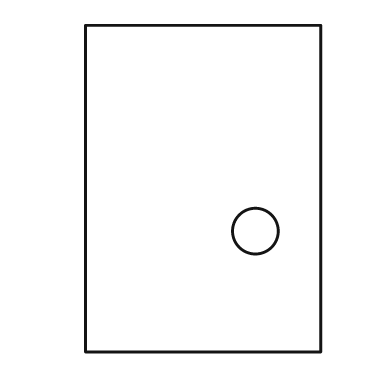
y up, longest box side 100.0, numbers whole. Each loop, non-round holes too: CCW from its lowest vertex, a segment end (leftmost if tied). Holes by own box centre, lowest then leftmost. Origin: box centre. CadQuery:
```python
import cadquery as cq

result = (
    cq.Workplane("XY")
    .moveTo(-36.0, -50.0)
    .lineTo(36.0, -50.0)
    .lineTo(36.0, 50.0)
    .lineTo(-36.0, 50.0)
    .close()
    .moveTo(16.0, -13.0)
    .circle(7.0)
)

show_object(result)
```